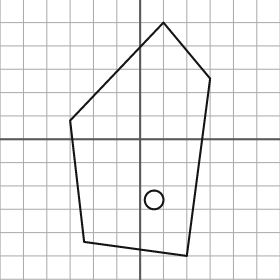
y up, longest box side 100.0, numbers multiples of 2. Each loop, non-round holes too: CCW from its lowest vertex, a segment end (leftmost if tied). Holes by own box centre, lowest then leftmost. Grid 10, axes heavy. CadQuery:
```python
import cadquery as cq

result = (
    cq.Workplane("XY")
    .moveTo(20.0, -50.0)
    .lineTo(30.0, 26.0)
    .lineTo(10.0, 50.0)
    .lineTo(-30.0, 8.0)
    .lineTo(-24.0, -44.0)
    .close()
    .moveTo(6.0, -26.0)
    .circle(4.0)
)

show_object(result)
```